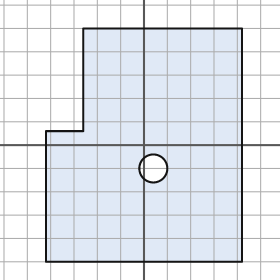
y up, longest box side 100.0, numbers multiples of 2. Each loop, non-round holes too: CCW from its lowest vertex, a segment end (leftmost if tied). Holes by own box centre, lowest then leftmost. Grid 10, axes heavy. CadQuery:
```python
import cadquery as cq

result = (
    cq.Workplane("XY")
    .moveTo(-42.0, -50.0)
    .lineTo(42.0, -50.0)
    .lineTo(42.0, 50.0)
    .lineTo(-26.0, 50.0)
    .lineTo(-26.0, 6.0)
    .lineTo(-42.0, 6.0)
    .close()
    .moveTo(4.0, -10.0)
    .circle(6.0)
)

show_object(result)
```